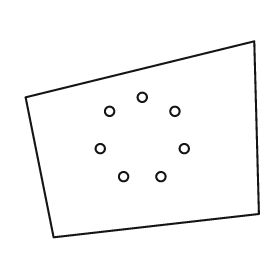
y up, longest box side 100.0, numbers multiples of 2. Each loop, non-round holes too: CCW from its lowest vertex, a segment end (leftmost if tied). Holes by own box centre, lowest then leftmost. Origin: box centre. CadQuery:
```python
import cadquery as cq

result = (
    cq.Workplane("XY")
    .moveTo(-38.0, -42.0)
    .lineTo(50.0, -32.0)
    .lineTo(48.0, 42.0)
    .lineTo(-50.0, 18.0)
    .close()
    .moveTo(-8.0, -16.0)
    .circle(2.0)
    .moveTo(8.0, -16.0)
    .circle(2.0)
    .moveTo(-18.0, -4.0)
    .circle(2.0)
    .moveTo(18.0, -4.0)
    .circle(2.0)
    .moveTo(-14.0, 12.0)
    .circle(2.0)
    .moveTo(14.0, 12.0)
    .circle(2.0)
    .moveTo(0.0, 18.0)
    .circle(2.0)
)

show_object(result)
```